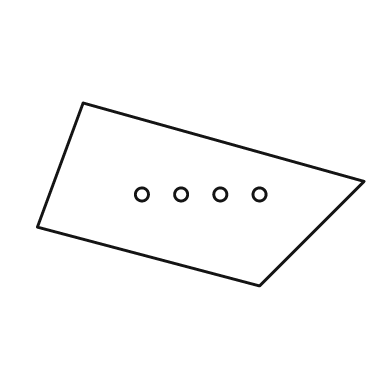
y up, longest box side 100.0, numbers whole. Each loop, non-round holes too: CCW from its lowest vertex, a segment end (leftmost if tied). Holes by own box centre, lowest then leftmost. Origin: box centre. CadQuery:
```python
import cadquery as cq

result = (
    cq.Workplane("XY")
    .moveTo(18.0, -28.0)
    .lineTo(50.0, 4.0)
    .lineTo(-36.0, 28.0)
    .lineTo(-50.0, -10.0)
    .close()
    .moveTo(-18.0, 0.0)
    .circle(2.0)
    .moveTo(-6.0, 0.0)
    .circle(2.0)
    .moveTo(6.0, 0.0)
    .circle(2.0)
    .moveTo(18.0, 0.0)
    .circle(2.0)
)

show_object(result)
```